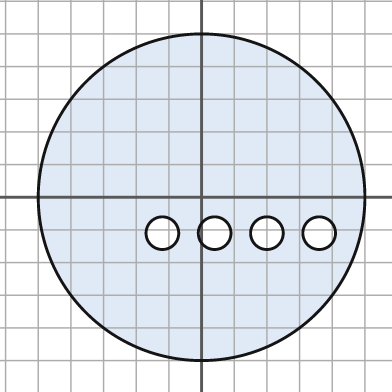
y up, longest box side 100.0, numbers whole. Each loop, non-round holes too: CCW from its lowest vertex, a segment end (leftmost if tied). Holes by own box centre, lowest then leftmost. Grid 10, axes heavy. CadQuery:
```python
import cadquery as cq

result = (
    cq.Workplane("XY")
    .moveTo(0.0, 0.0)
    .circle(50.0)
    .moveTo(-12.0, -11.0)
    .circle(5.0)
    .moveTo(4.0, -11.0)
    .circle(5.0)
    .moveTo(20.0, -11.0)
    .circle(5.0)
    .moveTo(36.0, -11.0)
    .circle(5.0)
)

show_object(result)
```